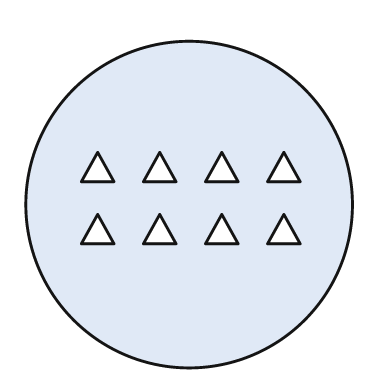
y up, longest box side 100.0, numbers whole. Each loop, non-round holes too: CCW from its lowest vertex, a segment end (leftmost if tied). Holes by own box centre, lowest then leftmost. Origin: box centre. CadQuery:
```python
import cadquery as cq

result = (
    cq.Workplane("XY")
    .moveTo(0.0, 0.0)
    .circle(50.0)
    .moveTo(-33.0, -12.0)
    .lineTo(-23.0, -12.0)
    .lineTo(-28.0, -3.0)
    .close()
    .moveTo(-14.0, -12.0)
    .lineTo(-4.0, -12.0)
    .lineTo(-9.0, -3.0)
    .close()
    .moveTo(5.0, -12.0)
    .lineTo(15.0, -12.0)
    .lineTo(10.0, -3.0)
    .close()
    .moveTo(24.0, -12.0)
    .lineTo(34.0, -12.0)
    .lineTo(29.0, -3.0)
    .close()
    .moveTo(-33.0, 7.0)
    .lineTo(-23.0, 7.0)
    .lineTo(-28.0, 16.0)
    .close()
    .moveTo(-14.0, 7.0)
    .lineTo(-4.0, 7.0)
    .lineTo(-9.0, 16.0)
    .close()
    .moveTo(5.0, 7.0)
    .lineTo(15.0, 7.0)
    .lineTo(10.0, 16.0)
    .close()
    .moveTo(24.0, 7.0)
    .lineTo(34.0, 7.0)
    .lineTo(29.0, 16.0)
    .close()
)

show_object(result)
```